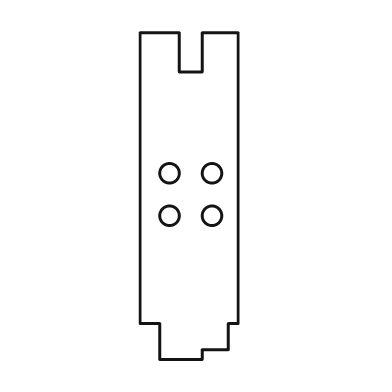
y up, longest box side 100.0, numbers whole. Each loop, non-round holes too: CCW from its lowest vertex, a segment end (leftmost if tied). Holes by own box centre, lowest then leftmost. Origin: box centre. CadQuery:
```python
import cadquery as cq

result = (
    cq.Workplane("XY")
    .moveTo(-9.0, -50.0)
    .lineTo(4.0, -50.0)
    .lineTo(4.0, -47.0)
    .lineTo(12.0, -47.0)
    .lineTo(12.0, -39.0)
    .lineTo(15.0, -39.0)
    .lineTo(15.0, 50.0)
    .lineTo(4.0, 50.0)
    .lineTo(4.0, 38.0)
    .lineTo(-3.0, 38.0)
    .lineTo(-3.0, 50.0)
    .lineTo(-15.0, 50.0)
    .lineTo(-15.0, -39.0)
    .lineTo(-9.0, -39.0)
    .close()
    .moveTo(-6.0, -6.0)
    .circle(3.0)
    .moveTo(7.0, -6.0)
    .circle(3.0)
    .moveTo(-6.0, 7.0)
    .circle(3.0)
    .moveTo(7.0, 7.0)
    .circle(3.0)
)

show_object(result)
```